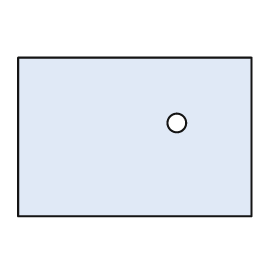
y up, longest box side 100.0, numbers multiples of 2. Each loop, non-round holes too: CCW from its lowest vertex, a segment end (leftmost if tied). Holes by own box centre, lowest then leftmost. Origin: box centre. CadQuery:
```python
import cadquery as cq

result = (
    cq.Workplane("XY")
    .moveTo(-50.0, -34.0)
    .lineTo(50.0, -34.0)
    .lineTo(50.0, 34.0)
    .lineTo(-50.0, 34.0)
    .close()
    .moveTo(18.0, 6.0)
    .circle(4.0)
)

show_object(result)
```